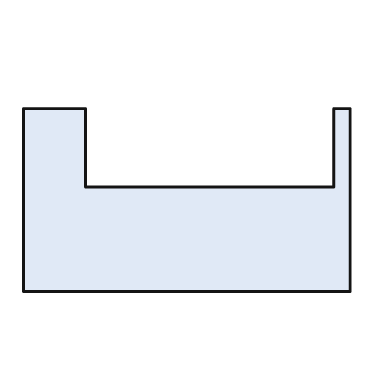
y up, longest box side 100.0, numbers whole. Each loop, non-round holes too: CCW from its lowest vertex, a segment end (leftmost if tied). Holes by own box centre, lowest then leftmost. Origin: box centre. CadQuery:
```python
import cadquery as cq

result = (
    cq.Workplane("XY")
    .moveTo(-50.0, -28.0)
    .lineTo(50.0, -28.0)
    .lineTo(50.0, 28.0)
    .lineTo(45.0, 28.0)
    .lineTo(45.0, 4.0)
    .lineTo(-31.0, 4.0)
    .lineTo(-31.0, 28.0)
    .lineTo(-50.0, 28.0)
    .close()
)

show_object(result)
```